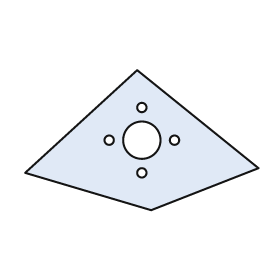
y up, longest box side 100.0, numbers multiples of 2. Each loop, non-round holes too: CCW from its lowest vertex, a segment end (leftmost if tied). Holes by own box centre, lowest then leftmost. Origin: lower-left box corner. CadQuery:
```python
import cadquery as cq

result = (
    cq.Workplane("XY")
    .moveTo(54.0, 0.0)
    .lineTo(100.0, 18.0)
    .lineTo(48.0, 60.0)
    .lineTo(0.0, 16.0)
    .close()
    .moveTo(50.0, 16.0)
    .circle(2.0)
    .moveTo(36.0, 30.0)
    .circle(2.0)
    .moveTo(50.0, 30.0)
    .circle(8.0)
    .moveTo(64.0, 30.0)
    .circle(2.0)
    .moveTo(50.0, 44.0)
    .circle(2.0)
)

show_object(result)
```